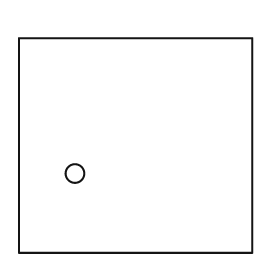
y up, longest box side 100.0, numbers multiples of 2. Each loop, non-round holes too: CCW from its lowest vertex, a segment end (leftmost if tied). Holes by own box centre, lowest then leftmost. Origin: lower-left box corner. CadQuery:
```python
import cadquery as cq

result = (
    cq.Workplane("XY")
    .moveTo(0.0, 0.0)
    .lineTo(100.0, 0.0)
    .lineTo(100.0, 92.0)
    .lineTo(0.0, 92.0)
    .close()
    .moveTo(24.0, 34.0)
    .circle(4.0)
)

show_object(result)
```